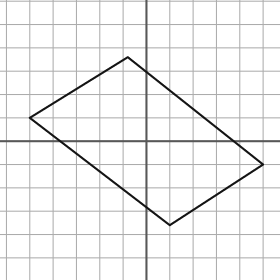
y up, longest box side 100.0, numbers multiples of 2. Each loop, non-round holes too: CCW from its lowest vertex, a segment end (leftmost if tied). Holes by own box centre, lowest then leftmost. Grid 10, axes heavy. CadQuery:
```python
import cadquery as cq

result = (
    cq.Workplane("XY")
    .moveTo(10.0, -36.0)
    .lineTo(50.0, -10.0)
    .lineTo(-8.0, 36.0)
    .lineTo(-50.0, 10.0)
    .close()
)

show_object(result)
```